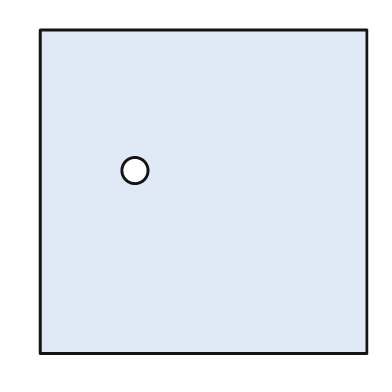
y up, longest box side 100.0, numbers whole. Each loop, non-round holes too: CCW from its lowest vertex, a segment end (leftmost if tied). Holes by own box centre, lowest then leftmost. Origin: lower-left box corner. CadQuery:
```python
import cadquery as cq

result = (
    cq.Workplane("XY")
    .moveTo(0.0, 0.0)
    .lineTo(100.0, 0.0)
    .lineTo(100.0, 99.0)
    .lineTo(0.0, 99.0)
    .close()
    .moveTo(29.0, 56.0)
    .circle(4.0)
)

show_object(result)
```